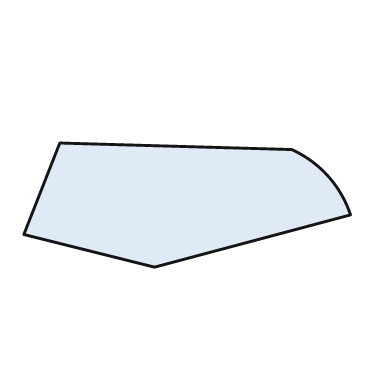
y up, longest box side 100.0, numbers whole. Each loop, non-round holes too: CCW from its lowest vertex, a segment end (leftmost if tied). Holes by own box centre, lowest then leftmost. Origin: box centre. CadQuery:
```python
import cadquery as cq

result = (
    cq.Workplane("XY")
    .moveTo(-10.0, -19.0)
    .lineTo(50.0, -3.0)
    .threePointArc((43.0, 9.0), (32.0, 17.0))
    .lineTo(-39.0, 19.0)
    .lineTo(-50.0, -9.0)
    .close()
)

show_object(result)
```